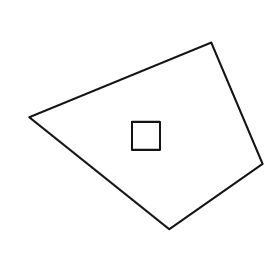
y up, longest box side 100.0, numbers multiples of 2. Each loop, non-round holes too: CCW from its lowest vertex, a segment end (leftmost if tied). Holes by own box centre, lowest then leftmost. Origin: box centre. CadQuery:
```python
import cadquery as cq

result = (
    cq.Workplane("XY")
    .moveTo(10.0, -40.0)
    .lineTo(50.0, -12.0)
    .lineTo(28.0, 40.0)
    .lineTo(-50.0, 8.0)
    .close()
    .moveTo(-6.0, -6.0)
    .lineTo(6.0, -6.0)
    .lineTo(6.0, 6.0)
    .lineTo(-6.0, 6.0)
    .close()
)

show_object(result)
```